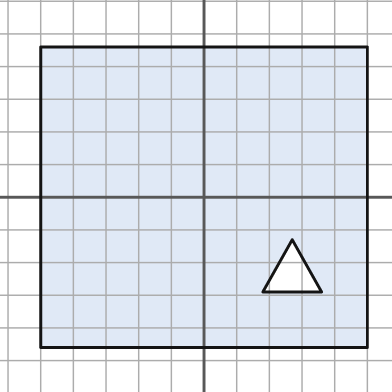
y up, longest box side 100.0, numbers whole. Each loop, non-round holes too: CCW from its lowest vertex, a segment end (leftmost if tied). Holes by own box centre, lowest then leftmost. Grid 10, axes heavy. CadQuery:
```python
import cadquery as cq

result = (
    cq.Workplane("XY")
    .moveTo(-50.0, -46.0)
    .lineTo(50.0, -46.0)
    .lineTo(50.0, 46.0)
    .lineTo(-50.0, 46.0)
    .close()
    .moveTo(18.0, -29.0)
    .lineTo(36.0, -29.0)
    .lineTo(27.0, -13.0)
    .close()
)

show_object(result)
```